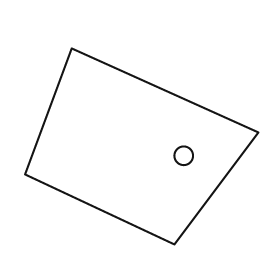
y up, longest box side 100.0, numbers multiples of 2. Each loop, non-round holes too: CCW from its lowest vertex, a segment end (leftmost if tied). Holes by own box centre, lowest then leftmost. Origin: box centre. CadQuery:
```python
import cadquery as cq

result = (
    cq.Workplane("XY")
    .moveTo(14.0, -42.0)
    .lineTo(50.0, 6.0)
    .lineTo(-30.0, 42.0)
    .lineTo(-50.0, -12.0)
    .close()
    .moveTo(18.0, -4.0)
    .circle(4.0)
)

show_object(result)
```